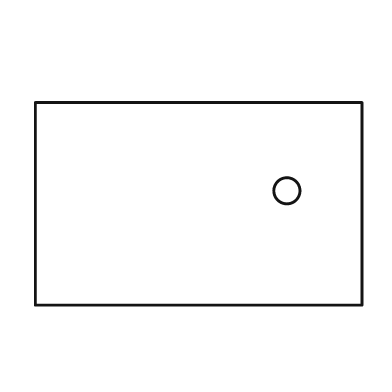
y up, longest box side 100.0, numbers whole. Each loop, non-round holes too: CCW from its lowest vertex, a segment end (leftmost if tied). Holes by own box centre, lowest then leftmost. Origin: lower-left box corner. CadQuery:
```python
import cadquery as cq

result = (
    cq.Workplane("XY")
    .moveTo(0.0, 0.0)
    .lineTo(100.0, 0.0)
    .lineTo(100.0, 62.0)
    .lineTo(0.0, 62.0)
    .close()
    .moveTo(77.0, 35.0)
    .circle(4.0)
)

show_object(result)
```